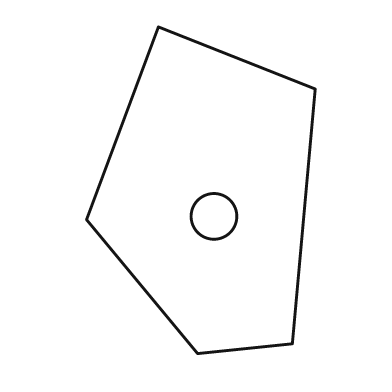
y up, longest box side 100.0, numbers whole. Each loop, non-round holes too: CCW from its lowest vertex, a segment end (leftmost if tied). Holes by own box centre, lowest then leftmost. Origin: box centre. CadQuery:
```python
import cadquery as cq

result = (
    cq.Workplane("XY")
    .moveTo(-1.0, -50.0)
    .lineTo(28.0, -47.0)
    .lineTo(35.0, 31.0)
    .lineTo(-13.0, 50.0)
    .lineTo(-35.0, -9.0)
    .close()
    .moveTo(4.0, -8.0)
    .circle(7.0)
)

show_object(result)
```